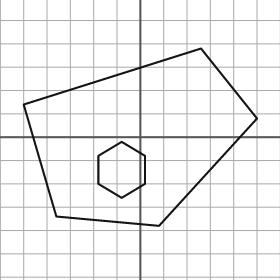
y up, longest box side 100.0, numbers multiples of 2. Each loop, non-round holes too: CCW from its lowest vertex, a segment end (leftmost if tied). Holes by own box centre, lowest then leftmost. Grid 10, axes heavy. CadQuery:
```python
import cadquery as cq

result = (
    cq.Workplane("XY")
    .moveTo(8.0, -38.0)
    .lineTo(50.0, 8.0)
    .lineTo(26.0, 38.0)
    .lineTo(-50.0, 14.0)
    .lineTo(-36.0, -34.0)
    .close()
    .moveTo(-8.0, -26.0)
    .lineTo(2.0, -20.0)
    .lineTo(2.0, -8.0)
    .lineTo(-8.0, -2.0)
    .lineTo(-18.0, -8.0)
    .lineTo(-18.0, -20.0)
    .close()
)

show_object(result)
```